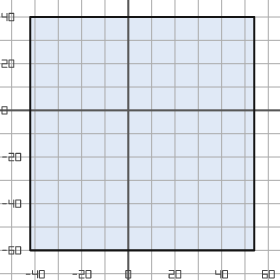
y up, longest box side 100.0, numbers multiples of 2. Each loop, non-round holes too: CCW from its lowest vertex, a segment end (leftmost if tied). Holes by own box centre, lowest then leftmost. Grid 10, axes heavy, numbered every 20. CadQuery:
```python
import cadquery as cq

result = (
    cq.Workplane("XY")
    .moveTo(-42.0, -60.0)
    .lineTo(54.0, -60.0)
    .lineTo(54.0, 40.0)
    .lineTo(-42.0, 40.0)
    .close()
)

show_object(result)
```